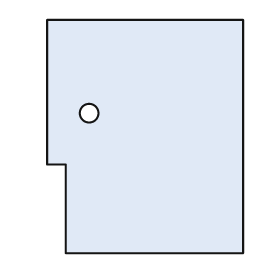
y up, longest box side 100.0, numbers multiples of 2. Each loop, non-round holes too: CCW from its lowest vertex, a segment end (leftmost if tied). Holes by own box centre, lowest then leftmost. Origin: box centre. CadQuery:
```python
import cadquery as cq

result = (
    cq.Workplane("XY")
    .moveTo(-34.0, -50.0)
    .lineTo(42.0, -50.0)
    .lineTo(42.0, 50.0)
    .lineTo(-42.0, 50.0)
    .lineTo(-42.0, -12.0)
    .lineTo(-34.0, -12.0)
    .close()
    .moveTo(-24.0, 10.0)
    .circle(4.0)
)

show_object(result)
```